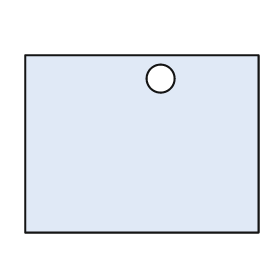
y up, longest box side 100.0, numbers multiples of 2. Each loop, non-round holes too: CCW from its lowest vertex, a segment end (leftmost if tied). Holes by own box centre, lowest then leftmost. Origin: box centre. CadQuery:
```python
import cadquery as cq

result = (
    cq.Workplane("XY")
    .moveTo(-50.0, -38.0)
    .lineTo(50.0, -38.0)
    .lineTo(50.0, 38.0)
    .lineTo(-50.0, 38.0)
    .close()
    .moveTo(8.0, 28.0)
    .circle(6.0)
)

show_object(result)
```